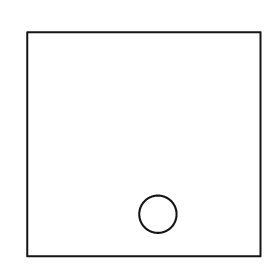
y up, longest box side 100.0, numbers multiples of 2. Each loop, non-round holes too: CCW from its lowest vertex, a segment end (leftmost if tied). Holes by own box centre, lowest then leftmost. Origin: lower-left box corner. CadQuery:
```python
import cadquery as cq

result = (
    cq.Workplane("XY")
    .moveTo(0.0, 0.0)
    .lineTo(100.0, 0.0)
    .lineTo(100.0, 96.0)
    .lineTo(0.0, 96.0)
    .close()
    .moveTo(56.0, 18.0)
    .circle(8.0)
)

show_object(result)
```